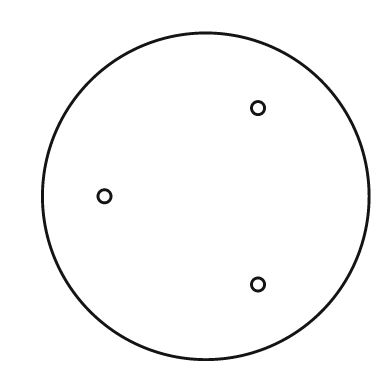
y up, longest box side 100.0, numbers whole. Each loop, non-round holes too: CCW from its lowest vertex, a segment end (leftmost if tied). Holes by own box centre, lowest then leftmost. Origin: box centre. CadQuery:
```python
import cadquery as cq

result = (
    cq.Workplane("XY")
    .moveTo(0.0, 0.0)
    .circle(50.0)
    .moveTo(16.0, -27.0)
    .circle(2.0)
    .moveTo(-31.0, 0.0)
    .circle(2.0)
    .moveTo(16.0, 27.0)
    .circle(2.0)
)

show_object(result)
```